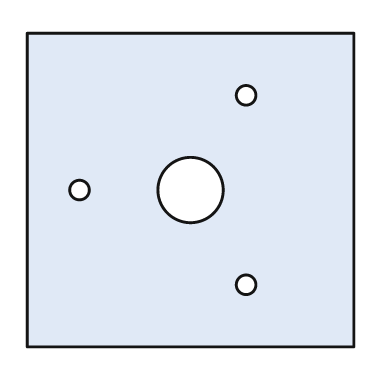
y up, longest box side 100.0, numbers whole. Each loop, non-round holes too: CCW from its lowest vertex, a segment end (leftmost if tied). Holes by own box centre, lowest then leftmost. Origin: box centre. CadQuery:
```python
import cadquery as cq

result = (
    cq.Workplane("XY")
    .moveTo(-50.0, -48.0)
    .lineTo(50.0, -48.0)
    .lineTo(50.0, 48.0)
    .lineTo(-50.0, 48.0)
    .close()
    .moveTo(17.0, -29.0)
    .circle(3.0)
    .moveTo(-34.0, 0.0)
    .circle(3.0)
    .moveTo(0.0, 0.0)
    .circle(10.0)
    .moveTo(17.0, 29.0)
    .circle(3.0)
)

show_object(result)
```